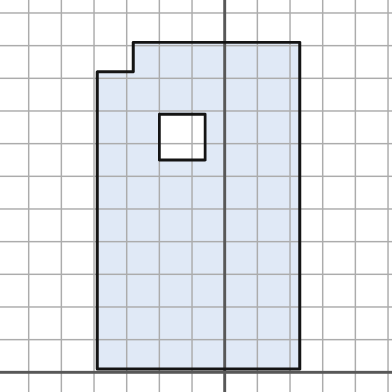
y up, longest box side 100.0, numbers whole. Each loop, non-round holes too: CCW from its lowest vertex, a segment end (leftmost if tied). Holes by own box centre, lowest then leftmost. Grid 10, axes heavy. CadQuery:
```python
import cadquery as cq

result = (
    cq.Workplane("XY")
    .moveTo(-39.0, 1.0)
    .lineTo(23.0, 1.0)
    .lineTo(23.0, 101.0)
    .lineTo(-28.0, 101.0)
    .lineTo(-28.0, 92.0)
    .lineTo(-39.0, 92.0)
    .close()
    .moveTo(-20.0, 65.0)
    .lineTo(-6.0, 65.0)
    .lineTo(-6.0, 79.0)
    .lineTo(-20.0, 79.0)
    .close()
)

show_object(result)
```